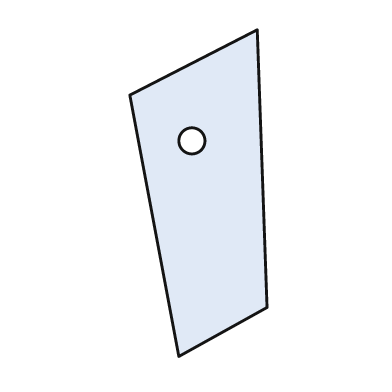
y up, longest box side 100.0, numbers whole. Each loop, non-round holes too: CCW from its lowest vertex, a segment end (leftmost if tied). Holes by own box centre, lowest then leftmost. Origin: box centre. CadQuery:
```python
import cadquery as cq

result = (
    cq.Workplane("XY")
    .moveTo(-6.0, -50.0)
    .lineTo(21.0, -35.0)
    .lineTo(18.0, 50.0)
    .lineTo(-21.0, 30.0)
    .close()
    .moveTo(-2.0, 16.0)
    .circle(4.0)
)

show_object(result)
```